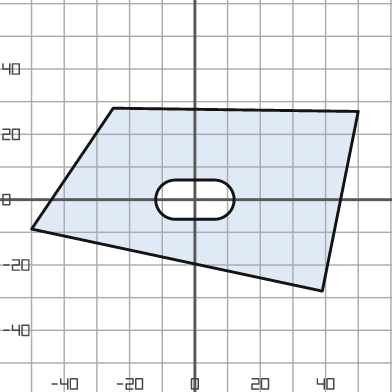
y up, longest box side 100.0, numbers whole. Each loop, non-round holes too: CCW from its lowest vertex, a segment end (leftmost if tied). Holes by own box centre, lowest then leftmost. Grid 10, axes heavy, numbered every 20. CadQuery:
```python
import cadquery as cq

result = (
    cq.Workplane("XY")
    .moveTo(39.0, -28.0)
    .lineTo(50.0, 27.0)
    .lineTo(-25.0, 28.0)
    .lineTo(-50.0, -9.0)
    .close()
    .moveTo(-6.0, -6.0)
    .lineTo(6.0, -6.0)
    .threePointArc((12.0, 0.0), (6.0, 6.0))
    .lineTo(-6.0, 6.0)
    .threePointArc((-12.0, 0.0), (-6.0, -6.0))
    .close()
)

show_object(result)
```